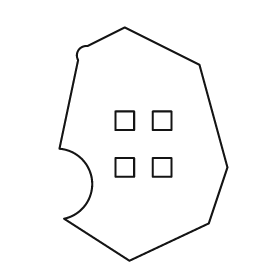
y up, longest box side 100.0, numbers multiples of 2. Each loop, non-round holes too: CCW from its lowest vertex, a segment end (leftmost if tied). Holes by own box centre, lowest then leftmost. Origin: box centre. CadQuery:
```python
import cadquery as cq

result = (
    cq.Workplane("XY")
    .moveTo(-6.0, -50.0)
    .lineTo(28.0, -34.0)
    .lineTo(36.0, -10.0)
    .lineTo(24.0, 34.0)
    .lineTo(-8.0, 50.0)
    .lineTo(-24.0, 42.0)
    .threePointArc((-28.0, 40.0), (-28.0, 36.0))
    .lineTo(-36.0, -2.0)
    .threePointArc((-22.0, -16.0), (-34.0, -32.0))
    .close()
    .moveTo(-12.0, -14.0)
    .lineTo(-4.0, -14.0)
    .lineTo(-4.0, -6.0)
    .lineTo(-12.0, -6.0)
    .close()
    .moveTo(4.0, -14.0)
    .lineTo(12.0, -14.0)
    .lineTo(12.0, -6.0)
    .lineTo(4.0, -6.0)
    .close()
    .moveTo(-12.0, 6.0)
    .lineTo(-4.0, 6.0)
    .lineTo(-4.0, 14.0)
    .lineTo(-12.0, 14.0)
    .close()
    .moveTo(4.0, 6.0)
    .lineTo(12.0, 6.0)
    .lineTo(12.0, 14.0)
    .lineTo(4.0, 14.0)
    .close()
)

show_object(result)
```